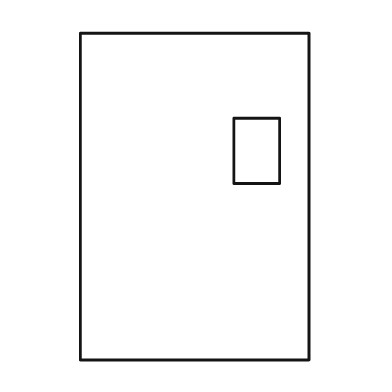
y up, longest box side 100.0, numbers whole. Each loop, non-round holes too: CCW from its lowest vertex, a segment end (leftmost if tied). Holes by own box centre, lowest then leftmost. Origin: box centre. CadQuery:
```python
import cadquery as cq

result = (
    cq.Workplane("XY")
    .moveTo(-35.0, -50.0)
    .lineTo(35.0, -50.0)
    .lineTo(35.0, 50.0)
    .lineTo(-35.0, 50.0)
    .close()
    .moveTo(12.0, 4.0)
    .lineTo(26.0, 4.0)
    .lineTo(26.0, 24.0)
    .lineTo(12.0, 24.0)
    .close()
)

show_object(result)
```